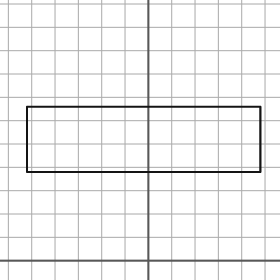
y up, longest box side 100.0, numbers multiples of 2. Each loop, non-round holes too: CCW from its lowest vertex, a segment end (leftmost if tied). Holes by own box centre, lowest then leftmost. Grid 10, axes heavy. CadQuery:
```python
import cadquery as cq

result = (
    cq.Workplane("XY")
    .moveTo(-52.0, 38.0)
    .lineTo(48.0, 38.0)
    .lineTo(48.0, 66.0)
    .lineTo(-52.0, 66.0)
    .close()
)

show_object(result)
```